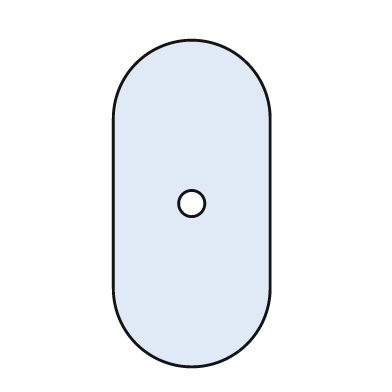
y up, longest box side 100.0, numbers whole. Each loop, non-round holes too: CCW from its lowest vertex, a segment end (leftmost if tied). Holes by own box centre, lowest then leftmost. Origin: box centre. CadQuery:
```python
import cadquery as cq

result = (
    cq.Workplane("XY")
    .moveTo(-24.0, -26.0)
    .threePointArc((0.0, -50.0), (24.0, -26.0))
    .lineTo(24.0, 26.0)
    .threePointArc((0.0, 50.0), (-24.0, 26.0))
    .close()
    .moveTo(0.0, 0.0)
    .circle(4.0)
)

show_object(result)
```